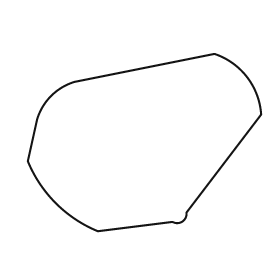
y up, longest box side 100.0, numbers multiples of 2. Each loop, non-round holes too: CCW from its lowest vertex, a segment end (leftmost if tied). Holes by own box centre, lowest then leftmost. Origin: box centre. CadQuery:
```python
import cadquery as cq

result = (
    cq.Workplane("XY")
    .moveTo(-20.0, -38.0)
    .lineTo(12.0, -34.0)
    .threePointArc((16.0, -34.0), (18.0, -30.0))
    .lineTo(50.0, 12.0)
    .threePointArc((44.0, 28.0), (30.0, 38.0))
    .lineTo(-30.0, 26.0)
    .threePointArc((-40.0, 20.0), (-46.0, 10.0))
    .lineTo(-50.0, -8.0)
    .threePointArc((-38.0, -26.0), (-20.0, -38.0))
    .close()
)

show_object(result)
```